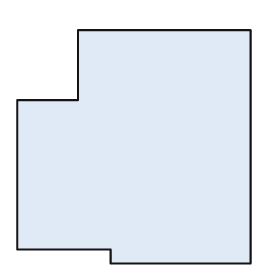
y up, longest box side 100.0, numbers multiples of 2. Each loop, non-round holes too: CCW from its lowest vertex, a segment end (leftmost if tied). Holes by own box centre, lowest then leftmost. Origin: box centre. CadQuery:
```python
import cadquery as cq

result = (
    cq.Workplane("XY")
    .moveTo(-10.0, -50.0)
    .lineTo(50.0, -50.0)
    .lineTo(50.0, 50.0)
    .lineTo(-24.0, 50.0)
    .lineTo(-24.0, 20.0)
    .lineTo(-50.0, 20.0)
    .lineTo(-50.0, -44.0)
    .lineTo(-10.0, -44.0)
    .close()
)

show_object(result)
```